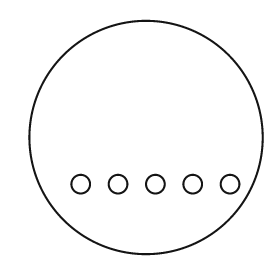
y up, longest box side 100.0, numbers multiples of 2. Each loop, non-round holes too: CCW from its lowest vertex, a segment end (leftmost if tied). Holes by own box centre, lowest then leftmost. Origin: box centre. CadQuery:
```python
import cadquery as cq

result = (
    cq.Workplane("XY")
    .moveTo(0.0, 0.0)
    .circle(50.0)
    .moveTo(-28.0, -20.0)
    .circle(4.0)
    .moveTo(-12.0, -20.0)
    .circle(4.0)
    .moveTo(4.0, -20.0)
    .circle(4.0)
    .moveTo(20.0, -20.0)
    .circle(4.0)
    .moveTo(36.0, -20.0)
    .circle(4.0)
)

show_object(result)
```